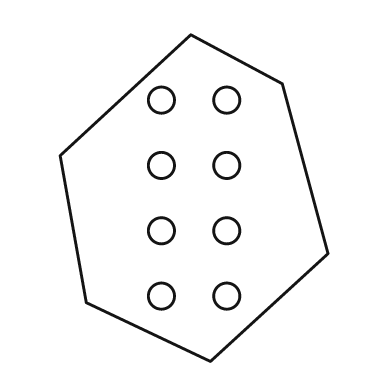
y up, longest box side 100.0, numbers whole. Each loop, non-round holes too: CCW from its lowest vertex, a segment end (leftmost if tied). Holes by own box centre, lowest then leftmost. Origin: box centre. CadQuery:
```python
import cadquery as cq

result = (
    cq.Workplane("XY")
    .moveTo(5.0, -50.0)
    .lineTo(41.0, -17.0)
    .lineTo(27.0, 35.0)
    .lineTo(-1.0, 50.0)
    .lineTo(-41.0, 13.0)
    .lineTo(-33.0, -32.0)
    .close()
    .moveTo(-10.0, -30.0)
    .circle(4.0)
    .moveTo(10.0, -30.0)
    .circle(4.0)
    .moveTo(-10.0, -10.0)
    .circle(4.0)
    .moveTo(10.0, -10.0)
    .circle(4.0)
    .moveTo(-10.0, 10.0)
    .circle(4.0)
    .moveTo(10.0, 10.0)
    .circle(4.0)
    .moveTo(-10.0, 30.0)
    .circle(4.0)
    .moveTo(10.0, 30.0)
    .circle(4.0)
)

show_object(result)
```